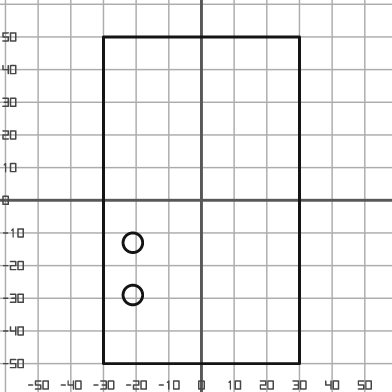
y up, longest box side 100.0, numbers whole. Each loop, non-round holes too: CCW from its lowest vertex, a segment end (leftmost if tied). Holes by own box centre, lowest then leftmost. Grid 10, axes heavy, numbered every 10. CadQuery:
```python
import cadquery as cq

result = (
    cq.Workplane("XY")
    .moveTo(-30.0, -50.0)
    .lineTo(30.0, -50.0)
    .lineTo(30.0, 50.0)
    .lineTo(-30.0, 50.0)
    .close()
    .moveTo(-21.0, -29.0)
    .circle(3.0)
    .moveTo(-21.0, -13.0)
    .circle(3.0)
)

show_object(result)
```